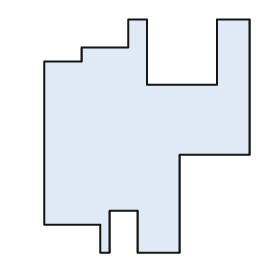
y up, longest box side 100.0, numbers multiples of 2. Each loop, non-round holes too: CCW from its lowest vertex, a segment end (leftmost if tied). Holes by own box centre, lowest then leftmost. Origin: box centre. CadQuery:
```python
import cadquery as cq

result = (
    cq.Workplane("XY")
    .moveTo(-20.0, -50.0)
    .lineTo(-16.0, -50.0)
    .lineTo(-16.0, -32.0)
    .lineTo(-4.0, -32.0)
    .lineTo(-4.0, -50.0)
    .lineTo(14.0, -50.0)
    .lineTo(14.0, -8.0)
    .lineTo(44.0, -8.0)
    .lineTo(44.0, 50.0)
    .lineTo(30.0, 50.0)
    .lineTo(30.0, 22.0)
    .lineTo(0.0, 22.0)
    .lineTo(0.0, 50.0)
    .lineTo(-8.0, 50.0)
    .lineTo(-8.0, 38.0)
    .lineTo(-28.0, 38.0)
    .lineTo(-28.0, 32.0)
    .lineTo(-44.0, 32.0)
    .lineTo(-44.0, -38.0)
    .lineTo(-20.0, -38.0)
    .close()
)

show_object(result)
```